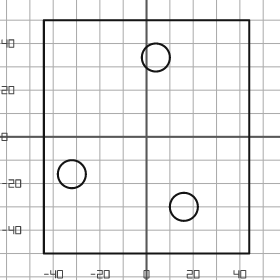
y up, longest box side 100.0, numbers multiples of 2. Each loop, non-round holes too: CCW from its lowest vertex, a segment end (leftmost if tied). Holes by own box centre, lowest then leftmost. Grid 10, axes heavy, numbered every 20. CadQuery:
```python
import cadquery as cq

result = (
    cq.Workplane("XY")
    .moveTo(-44.0, -50.0)
    .lineTo(44.0, -50.0)
    .lineTo(44.0, 50.0)
    .lineTo(-44.0, 50.0)
    .close()
    .moveTo(16.0, -30.0)
    .circle(6.0)
    .moveTo(-32.0, -16.0)
    .circle(6.0)
    .moveTo(4.0, 34.0)
    .circle(6.0)
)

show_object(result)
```